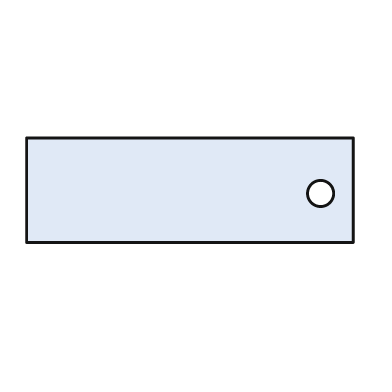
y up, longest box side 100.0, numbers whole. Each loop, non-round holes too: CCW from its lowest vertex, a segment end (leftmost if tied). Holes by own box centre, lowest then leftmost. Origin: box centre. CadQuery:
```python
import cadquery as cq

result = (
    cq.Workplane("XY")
    .moveTo(-50.0, -16.0)
    .lineTo(50.0, -16.0)
    .lineTo(50.0, 16.0)
    .lineTo(-50.0, 16.0)
    .close()
    .moveTo(40.0, -1.0)
    .circle(4.0)
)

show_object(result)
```